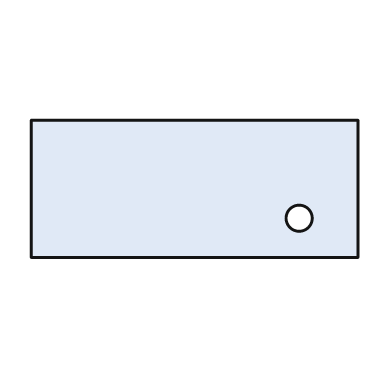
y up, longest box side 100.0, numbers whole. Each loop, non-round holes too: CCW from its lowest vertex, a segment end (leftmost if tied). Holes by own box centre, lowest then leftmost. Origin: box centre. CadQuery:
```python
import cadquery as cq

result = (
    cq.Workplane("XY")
    .moveTo(-50.0, -21.0)
    .lineTo(50.0, -21.0)
    .lineTo(50.0, 21.0)
    .lineTo(-50.0, 21.0)
    .close()
    .moveTo(32.0, -9.0)
    .circle(4.0)
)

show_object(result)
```